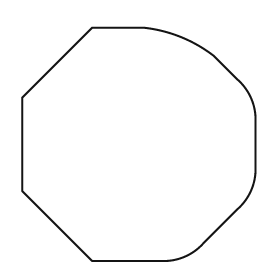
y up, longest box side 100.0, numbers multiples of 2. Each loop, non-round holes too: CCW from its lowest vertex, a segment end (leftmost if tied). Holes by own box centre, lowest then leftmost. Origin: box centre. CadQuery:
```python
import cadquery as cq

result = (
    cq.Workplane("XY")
    .moveTo(-20.0, -50.0)
    .lineTo(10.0, -50.0)
    .threePointArc((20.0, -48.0), (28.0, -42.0))
    .lineTo(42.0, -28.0)
    .threePointArc((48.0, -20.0), (50.0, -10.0))
    .lineTo(50.0, 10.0)
    .threePointArc((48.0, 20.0), (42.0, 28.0))
    .lineTo(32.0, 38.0)
    .threePointArc((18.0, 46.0), (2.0, 50.0))
    .lineTo(-20.0, 50.0)
    .lineTo(-50.0, 20.0)
    .lineTo(-50.0, -20.0)
    .close()
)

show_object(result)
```